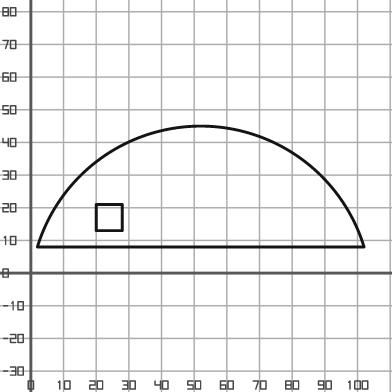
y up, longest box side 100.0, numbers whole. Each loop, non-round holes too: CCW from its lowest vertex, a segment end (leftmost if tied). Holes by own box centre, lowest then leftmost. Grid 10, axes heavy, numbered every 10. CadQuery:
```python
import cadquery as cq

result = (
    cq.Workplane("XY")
    .moveTo(2.0, 8.0)
    .lineTo(102.0, 8.0)
    .threePointArc((52.0, 45.0), (2.0, 8.0))
    .close()
    .moveTo(20.0, 13.0)
    .lineTo(28.0, 13.0)
    .lineTo(28.0, 21.0)
    .lineTo(20.0, 21.0)
    .close()
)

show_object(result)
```